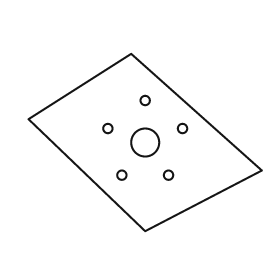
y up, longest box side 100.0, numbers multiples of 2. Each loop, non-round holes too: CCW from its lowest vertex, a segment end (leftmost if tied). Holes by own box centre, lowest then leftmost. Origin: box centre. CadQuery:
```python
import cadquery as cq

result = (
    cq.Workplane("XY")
    .moveTo(0.0, -38.0)
    .lineTo(50.0, -12.0)
    .lineTo(-6.0, 38.0)
    .lineTo(-50.0, 10.0)
    .close()
    .moveTo(-10.0, -14.0)
    .circle(2.0)
    .moveTo(10.0, -14.0)
    .circle(2.0)
    .moveTo(0.0, 0.0)
    .circle(6.0)
    .moveTo(-16.0, 6.0)
    .circle(2.0)
    .moveTo(16.0, 6.0)
    .circle(2.0)
    .moveTo(0.0, 18.0)
    .circle(2.0)
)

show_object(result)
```